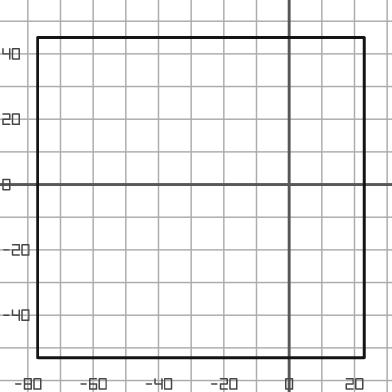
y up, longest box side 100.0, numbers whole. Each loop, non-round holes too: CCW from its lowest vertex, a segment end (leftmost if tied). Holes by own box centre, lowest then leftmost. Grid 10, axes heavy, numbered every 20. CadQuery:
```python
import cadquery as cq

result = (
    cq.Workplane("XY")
    .moveTo(-77.0, -53.0)
    .lineTo(23.0, -53.0)
    .lineTo(23.0, 45.0)
    .lineTo(-77.0, 45.0)
    .close()
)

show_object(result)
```